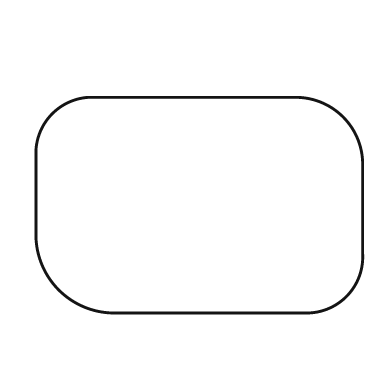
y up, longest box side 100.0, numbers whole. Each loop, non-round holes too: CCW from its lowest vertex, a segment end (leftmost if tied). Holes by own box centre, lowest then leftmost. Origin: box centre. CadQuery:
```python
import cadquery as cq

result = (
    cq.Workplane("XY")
    .moveTo(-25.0, -33.0)
    .lineTo(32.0, -33.0)
    .threePointArc((45.0, -28.0), (50.0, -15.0))
    .lineTo(50.0, 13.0)
    .threePointArc((44.0, 27.0), (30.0, 33.0))
    .lineTo(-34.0, 33.0)
    .threePointArc((-45.0, 28.0), (-50.0, 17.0))
    .lineTo(-50.0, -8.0)
    .threePointArc((-43.0, -26.0), (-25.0, -33.0))
    .close()
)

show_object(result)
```